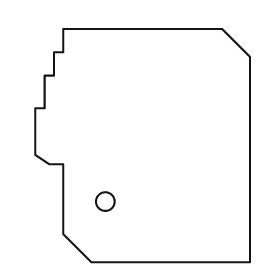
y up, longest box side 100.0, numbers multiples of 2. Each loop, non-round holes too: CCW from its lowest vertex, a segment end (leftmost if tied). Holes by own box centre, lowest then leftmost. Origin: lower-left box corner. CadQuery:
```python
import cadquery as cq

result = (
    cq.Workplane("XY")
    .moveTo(24.0, 0.0)
    .lineTo(92.0, 0.0)
    .lineTo(92.0, 88.0)
    .lineTo(80.0, 100.0)
    .lineTo(12.0, 100.0)
    .lineTo(12.0, 90.0)
    .lineTo(8.0, 90.0)
    .lineTo(8.0, 80.0)
    .lineTo(4.0, 80.0)
    .lineTo(4.0, 66.0)
    .lineTo(0.0, 66.0)
    .lineTo(0.0, 46.0)
    .lineTo(6.0, 42.0)
    .lineTo(12.0, 42.0)
    .lineTo(12.0, 12.0)
    .close()
    .moveTo(30.0, 26.0)
    .circle(4.0)
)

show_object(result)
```